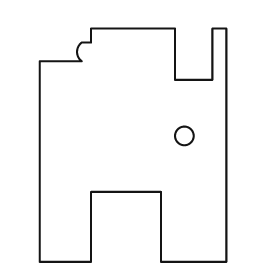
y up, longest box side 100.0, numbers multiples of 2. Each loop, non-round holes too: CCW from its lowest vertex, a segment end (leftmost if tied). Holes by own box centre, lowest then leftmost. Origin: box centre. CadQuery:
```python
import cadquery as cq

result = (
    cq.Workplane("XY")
    .moveTo(-40.0, -50.0)
    .lineTo(-18.0, -50.0)
    .lineTo(-18.0, -20.0)
    .lineTo(12.0, -20.0)
    .lineTo(12.0, -50.0)
    .lineTo(40.0, -50.0)
    .lineTo(40.0, 50.0)
    .lineTo(34.0, 50.0)
    .lineTo(34.0, 28.0)
    .lineTo(18.0, 28.0)
    .lineTo(18.0, 50.0)
    .lineTo(-18.0, 50.0)
    .lineTo(-18.0, 44.0)
    .lineTo(-22.0, 44.0)
    .threePointArc((-24.0, 40.0), (-22.0, 36.0))
    .lineTo(-40.0, 36.0)
    .close()
    .moveTo(22.0, 4.0)
    .circle(4.0)
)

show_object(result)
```